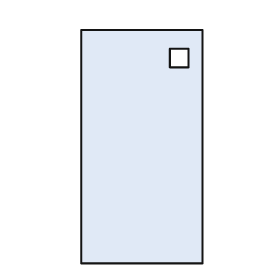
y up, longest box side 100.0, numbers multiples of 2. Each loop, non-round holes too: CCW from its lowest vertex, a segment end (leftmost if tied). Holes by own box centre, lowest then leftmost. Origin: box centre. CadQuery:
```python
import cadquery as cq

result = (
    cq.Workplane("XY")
    .moveTo(-26.0, -50.0)
    .lineTo(26.0, -50.0)
    .lineTo(26.0, 50.0)
    .lineTo(-26.0, 50.0)
    .close()
    .moveTo(12.0, 34.0)
    .lineTo(20.0, 34.0)
    .lineTo(20.0, 42.0)
    .lineTo(12.0, 42.0)
    .close()
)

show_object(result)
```